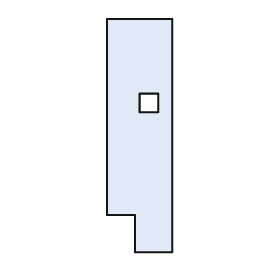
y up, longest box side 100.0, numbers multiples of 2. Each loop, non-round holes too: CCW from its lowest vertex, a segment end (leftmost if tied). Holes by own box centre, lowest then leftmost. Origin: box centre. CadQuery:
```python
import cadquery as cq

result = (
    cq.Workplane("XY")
    .moveTo(-2.0, -50.0)
    .lineTo(14.0, -50.0)
    .lineTo(14.0, 50.0)
    .lineTo(-14.0, 50.0)
    .lineTo(-14.0, -34.0)
    .lineTo(-2.0, -34.0)
    .close()
    .moveTo(0.0, 10.0)
    .lineTo(8.0, 10.0)
    .lineTo(8.0, 18.0)
    .lineTo(0.0, 18.0)
    .close()
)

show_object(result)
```